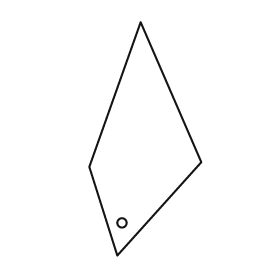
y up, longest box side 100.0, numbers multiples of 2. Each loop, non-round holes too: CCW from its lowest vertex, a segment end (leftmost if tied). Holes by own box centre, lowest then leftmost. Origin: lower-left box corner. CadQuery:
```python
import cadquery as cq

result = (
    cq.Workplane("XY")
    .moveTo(12.0, 0.0)
    .lineTo(48.0, 40.0)
    .lineTo(22.0, 100.0)
    .lineTo(0.0, 38.0)
    .close()
    .moveTo(14.0, 14.0)
    .circle(2.0)
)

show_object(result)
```